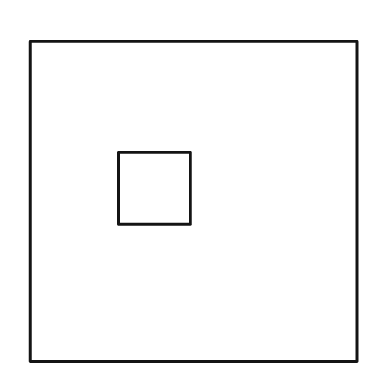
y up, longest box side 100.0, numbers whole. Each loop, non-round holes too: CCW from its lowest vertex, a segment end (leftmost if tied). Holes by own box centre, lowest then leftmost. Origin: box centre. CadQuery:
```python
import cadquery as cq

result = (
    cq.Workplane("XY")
    .moveTo(-50.0, -49.0)
    .lineTo(50.0, -49.0)
    .lineTo(50.0, 49.0)
    .lineTo(-50.0, 49.0)
    .close()
    .moveTo(-23.0, -7.0)
    .lineTo(-1.0, -7.0)
    .lineTo(-1.0, 15.0)
    .lineTo(-23.0, 15.0)
    .close()
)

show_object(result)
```